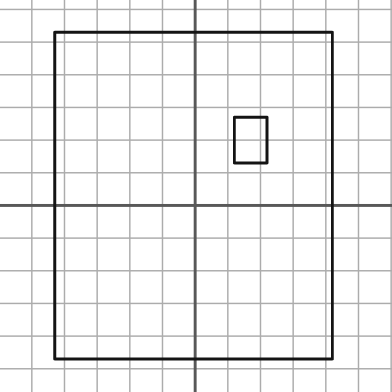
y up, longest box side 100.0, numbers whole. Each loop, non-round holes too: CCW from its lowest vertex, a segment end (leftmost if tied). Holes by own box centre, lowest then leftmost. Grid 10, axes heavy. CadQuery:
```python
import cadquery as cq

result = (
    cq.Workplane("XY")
    .moveTo(-43.0, -47.0)
    .lineTo(42.0, -47.0)
    .lineTo(42.0, 53.0)
    .lineTo(-43.0, 53.0)
    .close()
    .moveTo(12.0, 13.0)
    .lineTo(22.0, 13.0)
    .lineTo(22.0, 27.0)
    .lineTo(12.0, 27.0)
    .close()
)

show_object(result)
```